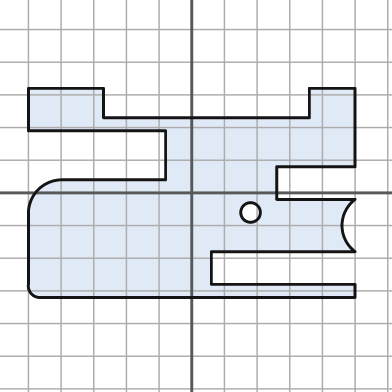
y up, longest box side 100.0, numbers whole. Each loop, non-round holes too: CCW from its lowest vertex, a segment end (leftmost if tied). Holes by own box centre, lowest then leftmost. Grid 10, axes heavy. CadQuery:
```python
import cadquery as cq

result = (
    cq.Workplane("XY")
    .moveTo(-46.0, -32.0)
    .lineTo(50.0, -32.0)
    .lineTo(50.0, -28.0)
    .lineTo(6.0, -28.0)
    .lineTo(6.0, -18.0)
    .lineTo(50.0, -18.0)
    .threePointArc((46.0, -10.0), (50.0, -2.0))
    .lineTo(26.0, -2.0)
    .lineTo(26.0, 8.0)
    .lineTo(50.0, 8.0)
    .lineTo(50.0, 32.0)
    .lineTo(36.0, 32.0)
    .lineTo(36.0, 23.0)
    .lineTo(-27.0, 23.0)
    .lineTo(-27.0, 32.0)
    .lineTo(-50.0, 32.0)
    .lineTo(-50.0, 19.0)
    .lineTo(-8.0, 19.0)
    .lineTo(-8.0, 4.0)
    .lineTo(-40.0, 4.0)
    .threePointArc((-47.0, 1.0), (-50.0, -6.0))
    .lineTo(-50.0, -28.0)
    .threePointArc((-49.0, -31.0), (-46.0, -32.0))
    .close()
    .moveTo(18.0, -6.0)
    .circle(3.0)
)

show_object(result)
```